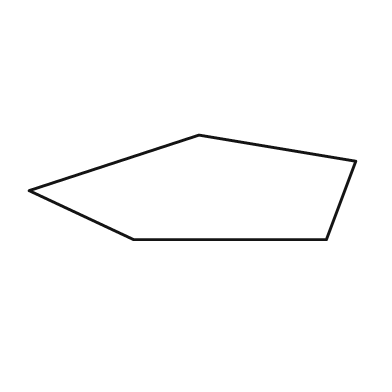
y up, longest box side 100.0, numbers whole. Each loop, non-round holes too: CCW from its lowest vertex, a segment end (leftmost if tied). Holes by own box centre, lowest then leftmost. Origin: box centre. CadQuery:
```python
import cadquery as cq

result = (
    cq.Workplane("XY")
    .moveTo(-18.0, -16.0)
    .lineTo(41.0, -16.0)
    .lineTo(50.0, 8.0)
    .lineTo(2.0, 16.0)
    .lineTo(-50.0, -1.0)
    .close()
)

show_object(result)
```